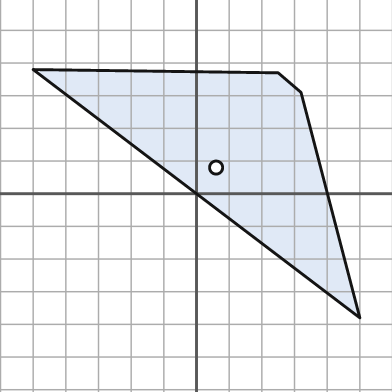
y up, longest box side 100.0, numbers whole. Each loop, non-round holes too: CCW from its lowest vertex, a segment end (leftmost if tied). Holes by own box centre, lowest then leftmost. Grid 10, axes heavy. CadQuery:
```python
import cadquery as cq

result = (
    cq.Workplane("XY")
    .moveTo(50.0, -38.0)
    .lineTo(32.0, 31.0)
    .lineTo(25.0, 37.0)
    .lineTo(-50.0, 38.0)
    .close()
    .moveTo(6.0, 8.0)
    .circle(2.0)
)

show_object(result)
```